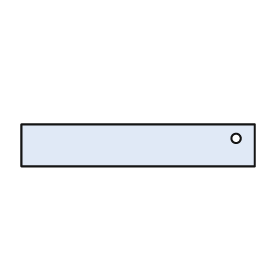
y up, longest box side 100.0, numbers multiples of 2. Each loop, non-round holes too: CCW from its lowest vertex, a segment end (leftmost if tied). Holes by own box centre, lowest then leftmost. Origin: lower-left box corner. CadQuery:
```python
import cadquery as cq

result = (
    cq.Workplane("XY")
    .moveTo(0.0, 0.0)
    .lineTo(100.0, 0.0)
    .lineTo(100.0, 18.0)
    .lineTo(0.0, 18.0)
    .close()
    .moveTo(92.0, 12.0)
    .circle(2.0)
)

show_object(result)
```